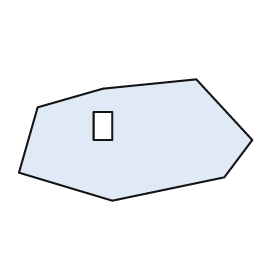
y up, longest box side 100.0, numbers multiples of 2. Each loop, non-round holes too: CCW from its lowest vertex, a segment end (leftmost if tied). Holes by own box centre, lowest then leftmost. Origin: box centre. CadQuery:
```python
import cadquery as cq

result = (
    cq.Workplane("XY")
    .moveTo(-10.0, -26.0)
    .lineTo(38.0, -16.0)
    .lineTo(50.0, 0.0)
    .lineTo(26.0, 26.0)
    .lineTo(-14.0, 22.0)
    .lineTo(-42.0, 14.0)
    .lineTo(-50.0, -14.0)
    .close()
    .moveTo(-18.0, 0.0)
    .lineTo(-10.0, 0.0)
    .lineTo(-10.0, 12.0)
    .lineTo(-18.0, 12.0)
    .close()
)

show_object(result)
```